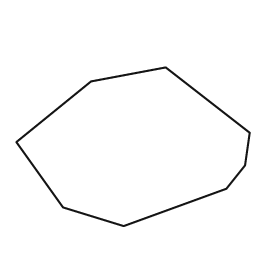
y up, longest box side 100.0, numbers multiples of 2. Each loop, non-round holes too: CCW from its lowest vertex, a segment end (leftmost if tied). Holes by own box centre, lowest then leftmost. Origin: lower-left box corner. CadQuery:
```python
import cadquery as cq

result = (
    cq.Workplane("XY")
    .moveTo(46.0, 0.0)
    .lineTo(90.0, 16.0)
    .lineTo(98.0, 26.0)
    .lineTo(100.0, 40.0)
    .lineTo(64.0, 68.0)
    .lineTo(32.0, 62.0)
    .lineTo(0.0, 36.0)
    .lineTo(20.0, 8.0)
    .close()
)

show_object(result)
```